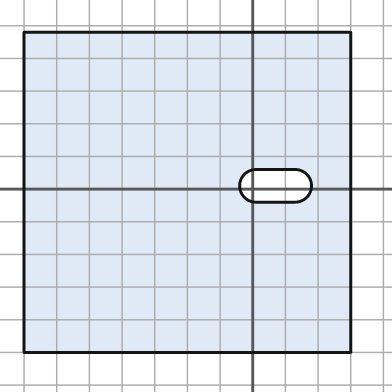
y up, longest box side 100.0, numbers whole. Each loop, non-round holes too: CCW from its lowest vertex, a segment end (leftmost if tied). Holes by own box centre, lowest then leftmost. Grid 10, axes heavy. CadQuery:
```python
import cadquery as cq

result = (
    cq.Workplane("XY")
    .moveTo(-70.0, -50.0)
    .lineTo(30.0, -50.0)
    .lineTo(30.0, 48.0)
    .lineTo(-70.0, 48.0)
    .close()
    .moveTo(1.0, -4.0)
    .lineTo(13.0, -4.0)
    .threePointArc((18.0, 1.0), (13.0, 6.0))
    .lineTo(1.0, 6.0)
    .threePointArc((-4.0, 1.0), (1.0, -4.0))
    .close()
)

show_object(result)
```